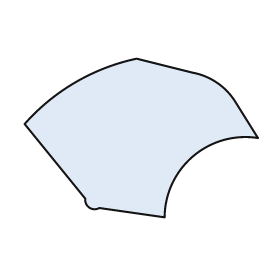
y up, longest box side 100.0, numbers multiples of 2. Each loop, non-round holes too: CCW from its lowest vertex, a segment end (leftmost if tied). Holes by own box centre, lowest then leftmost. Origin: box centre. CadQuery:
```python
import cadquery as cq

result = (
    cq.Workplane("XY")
    .moveTo(10.0, -34.0)
    .threePointArc((22.0, -8.0), (50.0, 0.0))
    .lineTo(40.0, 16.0)
    .threePointArc((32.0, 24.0), (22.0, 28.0))
    .lineTo(-2.0, 34.0)
    .threePointArc((-28.0, 24.0), (-50.0, 6.0))
    .lineTo(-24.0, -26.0)
    .threePointArc((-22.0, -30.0), (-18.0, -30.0))
    .close()
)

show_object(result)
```